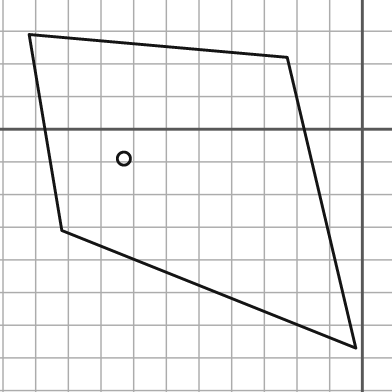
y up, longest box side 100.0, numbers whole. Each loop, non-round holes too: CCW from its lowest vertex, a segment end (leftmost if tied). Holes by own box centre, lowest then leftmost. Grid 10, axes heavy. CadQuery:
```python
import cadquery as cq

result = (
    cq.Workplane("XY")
    .moveTo(-2.0, -67.0)
    .lineTo(-23.0, 22.0)
    .lineTo(-102.0, 29.0)
    .lineTo(-92.0, -31.0)
    .close()
    .moveTo(-73.0, -9.0)
    .circle(2.0)
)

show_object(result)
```